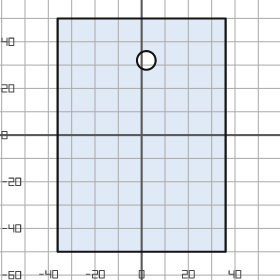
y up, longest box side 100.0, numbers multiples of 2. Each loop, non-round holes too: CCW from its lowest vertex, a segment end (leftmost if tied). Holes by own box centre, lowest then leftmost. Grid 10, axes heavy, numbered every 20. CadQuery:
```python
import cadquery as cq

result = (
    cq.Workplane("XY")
    .moveTo(-36.0, -50.0)
    .lineTo(36.0, -50.0)
    .lineTo(36.0, 50.0)
    .lineTo(-36.0, 50.0)
    .close()
    .moveTo(2.0, 32.0)
    .circle(4.0)
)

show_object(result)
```